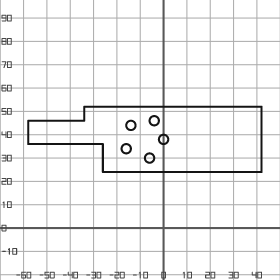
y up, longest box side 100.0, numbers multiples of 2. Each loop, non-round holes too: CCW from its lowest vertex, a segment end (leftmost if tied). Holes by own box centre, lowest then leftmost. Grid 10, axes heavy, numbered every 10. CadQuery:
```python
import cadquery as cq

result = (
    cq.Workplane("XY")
    .moveTo(-26.0, 24.0)
    .lineTo(42.0, 24.0)
    .lineTo(42.0, 52.0)
    .lineTo(-34.0, 52.0)
    .lineTo(-34.0, 46.0)
    .lineTo(-58.0, 46.0)
    .lineTo(-58.0, 36.0)
    .lineTo(-26.0, 36.0)
    .close()
    .moveTo(-6.0, 30.0)
    .circle(2.0)
    .moveTo(-16.0, 34.0)
    .circle(2.0)
    .moveTo(0.0, 38.0)
    .circle(2.0)
    .moveTo(-14.0, 44.0)
    .circle(2.0)
    .moveTo(-4.0, 46.0)
    .circle(2.0)
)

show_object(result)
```